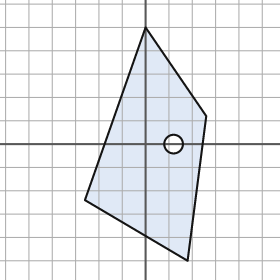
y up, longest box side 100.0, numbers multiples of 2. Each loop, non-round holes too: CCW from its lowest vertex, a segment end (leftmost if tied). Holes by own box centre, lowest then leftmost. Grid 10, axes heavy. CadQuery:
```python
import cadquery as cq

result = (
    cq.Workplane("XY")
    .moveTo(18.0, -50.0)
    .lineTo(26.0, 12.0)
    .lineTo(0.0, 50.0)
    .lineTo(-26.0, -24.0)
    .close()
    .moveTo(12.0, 0.0)
    .circle(4.0)
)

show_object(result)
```